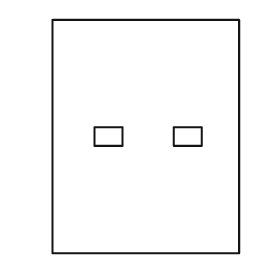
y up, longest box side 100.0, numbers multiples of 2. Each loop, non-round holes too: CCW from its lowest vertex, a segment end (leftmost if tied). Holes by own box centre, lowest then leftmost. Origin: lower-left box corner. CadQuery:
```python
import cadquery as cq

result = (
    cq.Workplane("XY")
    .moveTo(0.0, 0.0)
    .lineTo(80.0, 0.0)
    .lineTo(80.0, 100.0)
    .lineTo(0.0, 100.0)
    .close()
    .moveTo(18.0, 46.0)
    .lineTo(30.0, 46.0)
    .lineTo(30.0, 54.0)
    .lineTo(18.0, 54.0)
    .close()
    .moveTo(52.0, 46.0)
    .lineTo(64.0, 46.0)
    .lineTo(64.0, 54.0)
    .lineTo(52.0, 54.0)
    .close()
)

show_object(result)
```